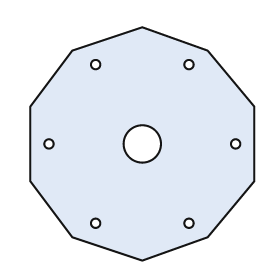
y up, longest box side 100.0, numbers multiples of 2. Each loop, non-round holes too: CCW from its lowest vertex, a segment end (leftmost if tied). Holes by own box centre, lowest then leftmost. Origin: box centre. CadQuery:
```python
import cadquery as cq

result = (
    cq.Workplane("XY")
    .moveTo(0.0, -50.0)
    .lineTo(28.0, -40.0)
    .lineTo(48.0, -16.0)
    .lineTo(48.0, 16.0)
    .lineTo(28.0, 40.0)
    .lineTo(0.0, 50.0)
    .lineTo(-30.0, 40.0)
    .lineTo(-48.0, 16.0)
    .lineTo(-48.0, -16.0)
    .lineTo(-30.0, -40.0)
    .close()
    .moveTo(-20.0, -34.0)
    .circle(2.0)
    .moveTo(20.0, -34.0)
    .circle(2.0)
    .moveTo(-40.0, 0.0)
    .circle(2.0)
    .moveTo(0.0, 0.0)
    .circle(8.0)
    .moveTo(40.0, 0.0)
    .circle(2.0)
    .moveTo(-20.0, 34.0)
    .circle(2.0)
    .moveTo(20.0, 34.0)
    .circle(2.0)
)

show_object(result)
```